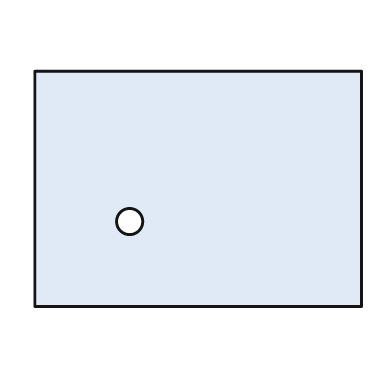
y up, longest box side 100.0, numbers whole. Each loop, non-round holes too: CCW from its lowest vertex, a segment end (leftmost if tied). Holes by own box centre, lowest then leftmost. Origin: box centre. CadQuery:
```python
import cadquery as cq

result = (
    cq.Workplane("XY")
    .moveTo(-50.0, -36.0)
    .lineTo(50.0, -36.0)
    .lineTo(50.0, 36.0)
    .lineTo(-50.0, 36.0)
    .close()
    .moveTo(-21.0, -10.0)
    .circle(4.0)
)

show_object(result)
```